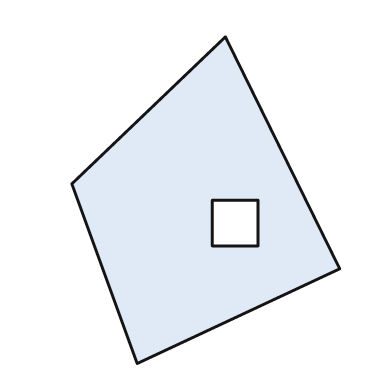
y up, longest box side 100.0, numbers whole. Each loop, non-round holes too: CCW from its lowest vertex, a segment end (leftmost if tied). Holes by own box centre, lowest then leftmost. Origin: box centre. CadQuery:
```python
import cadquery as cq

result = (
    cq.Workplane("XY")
    .moveTo(-21.0, -50.0)
    .lineTo(41.0, -21.0)
    .lineTo(6.0, 50.0)
    .lineTo(-41.0, 5.0)
    .close()
    .moveTo(2.0, -14.0)
    .lineTo(16.0, -14.0)
    .lineTo(16.0, 0.0)
    .lineTo(2.0, 0.0)
    .close()
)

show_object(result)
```